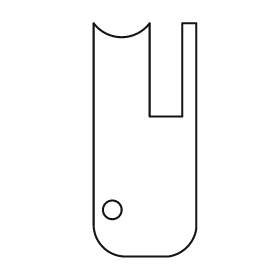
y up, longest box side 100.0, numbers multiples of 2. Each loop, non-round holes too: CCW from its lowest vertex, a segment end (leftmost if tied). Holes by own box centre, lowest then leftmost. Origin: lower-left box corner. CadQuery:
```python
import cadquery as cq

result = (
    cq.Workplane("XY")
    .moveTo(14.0, 0.0)
    .lineTo(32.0, 0.0)
    .threePointArc((40.0, 4.0), (44.0, 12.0))
    .lineTo(44.0, 100.0)
    .lineTo(38.0, 100.0)
    .lineTo(38.0, 60.0)
    .lineTo(24.0, 60.0)
    .lineTo(24.0, 100.0)
    .threePointArc((12.0, 94.0), (0.0, 100.0))
    .lineTo(0.0, 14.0)
    .threePointArc((4.0, 4.0), (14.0, 0.0))
    .close()
    .moveTo(8.0, 20.0)
    .circle(4.0)
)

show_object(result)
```